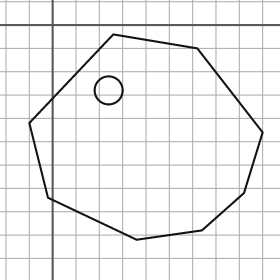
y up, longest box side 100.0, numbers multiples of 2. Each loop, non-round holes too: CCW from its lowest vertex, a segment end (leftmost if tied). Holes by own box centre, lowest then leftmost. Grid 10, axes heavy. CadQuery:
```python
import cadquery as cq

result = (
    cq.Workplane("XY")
    .moveTo(36.0, -92.0)
    .lineTo(64.0, -88.0)
    .lineTo(82.0, -72.0)
    .lineTo(90.0, -46.0)
    .lineTo(62.0, -10.0)
    .lineTo(26.0, -4.0)
    .lineTo(-10.0, -42.0)
    .lineTo(-2.0, -74.0)
    .close()
    .moveTo(24.0, -28.0)
    .circle(6.0)
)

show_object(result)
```